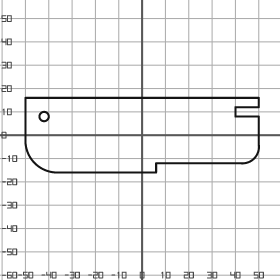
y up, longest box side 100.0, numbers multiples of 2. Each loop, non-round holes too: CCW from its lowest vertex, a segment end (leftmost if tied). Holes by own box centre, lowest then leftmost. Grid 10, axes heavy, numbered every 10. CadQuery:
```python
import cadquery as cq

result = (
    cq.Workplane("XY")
    .moveTo(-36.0, -16.0)
    .lineTo(6.0, -16.0)
    .lineTo(6.0, -12.0)
    .lineTo(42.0, -12.0)
    .threePointArc((48.0, -10.0), (50.0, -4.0))
    .lineTo(50.0, 8.0)
    .lineTo(40.0, 8.0)
    .lineTo(40.0, 12.0)
    .lineTo(50.0, 12.0)
    .lineTo(50.0, 16.0)
    .lineTo(-50.0, 16.0)
    .lineTo(-50.0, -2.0)
    .threePointArc((-46.0, -12.0), (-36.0, -16.0))
    .close()
    .moveTo(-42.0, 8.0)
    .circle(2.0)
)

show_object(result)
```